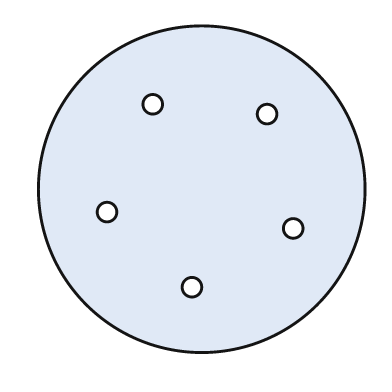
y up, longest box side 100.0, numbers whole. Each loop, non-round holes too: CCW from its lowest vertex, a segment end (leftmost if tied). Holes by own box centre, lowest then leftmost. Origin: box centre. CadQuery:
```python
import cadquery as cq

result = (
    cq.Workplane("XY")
    .moveTo(0.0, 0.0)
    .circle(50.0)
    .moveTo(-3.0, -30.0)
    .circle(3.0)
    .moveTo(28.0, -12.0)
    .circle(3.0)
    .moveTo(-29.0, -7.0)
    .circle(3.0)
    .moveTo(20.0, 23.0)
    .circle(3.0)
    .moveTo(-15.0, 26.0)
    .circle(3.0)
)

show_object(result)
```